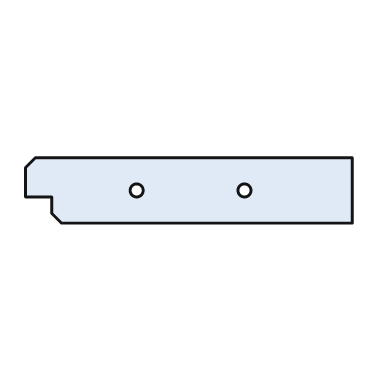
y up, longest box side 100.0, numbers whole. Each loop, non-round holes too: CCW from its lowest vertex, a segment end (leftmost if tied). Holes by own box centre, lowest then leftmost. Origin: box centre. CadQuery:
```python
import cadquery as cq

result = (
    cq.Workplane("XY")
    .moveTo(-39.0, -10.0)
    .lineTo(50.0, -10.0)
    .lineTo(50.0, 10.0)
    .lineTo(-47.0, 10.0)
    .lineTo(-50.0, 7.0)
    .lineTo(-50.0, -2.0)
    .lineTo(-42.0, -2.0)
    .lineTo(-42.0, -7.0)
    .close()
    .moveTo(-16.0, 0.0)
    .circle(2.0)
    .moveTo(17.0, 0.0)
    .circle(2.0)
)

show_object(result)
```